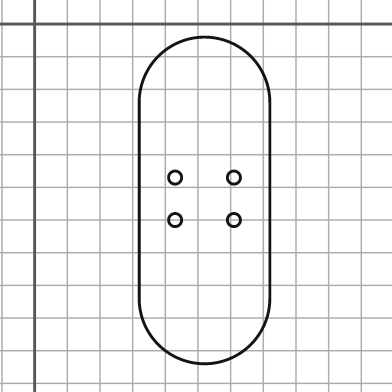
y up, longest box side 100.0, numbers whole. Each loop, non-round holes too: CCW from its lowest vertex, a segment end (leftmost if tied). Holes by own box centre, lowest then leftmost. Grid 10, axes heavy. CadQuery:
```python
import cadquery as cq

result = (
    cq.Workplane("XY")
    .moveTo(32.0, -84.0)
    .threePointArc((52.0, -104.0), (72.0, -84.0))
    .lineTo(72.0, -24.0)
    .threePointArc((52.0, -4.0), (32.0, -24.0))
    .close()
    .moveTo(43.0, -60.0)
    .circle(2.0)
    .moveTo(61.0, -60.0)
    .circle(2.0)
    .moveTo(43.0, -47.0)
    .circle(2.0)
    .moveTo(61.0, -47.0)
    .circle(2.0)
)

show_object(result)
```